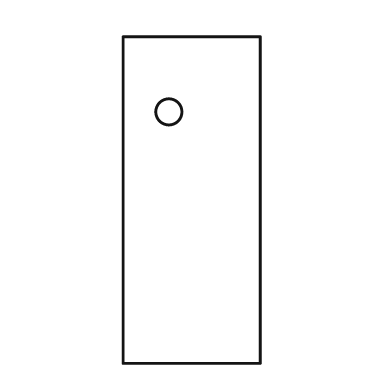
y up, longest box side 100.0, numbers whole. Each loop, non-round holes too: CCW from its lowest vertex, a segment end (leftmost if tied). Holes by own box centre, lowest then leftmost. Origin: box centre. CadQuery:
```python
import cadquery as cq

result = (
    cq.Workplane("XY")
    .moveTo(-21.0, -50.0)
    .lineTo(21.0, -50.0)
    .lineTo(21.0, 50.0)
    .lineTo(-21.0, 50.0)
    .close()
    .moveTo(-7.0, 27.0)
    .circle(4.0)
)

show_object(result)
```